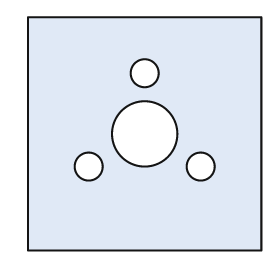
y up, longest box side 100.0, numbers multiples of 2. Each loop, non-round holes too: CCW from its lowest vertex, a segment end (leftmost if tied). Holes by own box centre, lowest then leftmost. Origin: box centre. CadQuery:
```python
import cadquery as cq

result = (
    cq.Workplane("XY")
    .moveTo(-50.0, -50.0)
    .lineTo(50.0, -50.0)
    .lineTo(50.0, 50.0)
    .lineTo(-50.0, 50.0)
    .close()
    .moveTo(-24.0, -14.0)
    .circle(6.0)
    .moveTo(24.0, -14.0)
    .circle(6.0)
    .moveTo(0.0, 0.0)
    .circle(14.0)
    .moveTo(0.0, 26.0)
    .circle(6.0)
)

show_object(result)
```